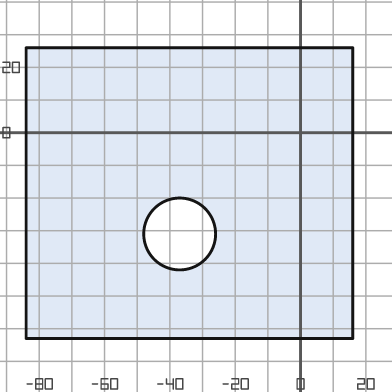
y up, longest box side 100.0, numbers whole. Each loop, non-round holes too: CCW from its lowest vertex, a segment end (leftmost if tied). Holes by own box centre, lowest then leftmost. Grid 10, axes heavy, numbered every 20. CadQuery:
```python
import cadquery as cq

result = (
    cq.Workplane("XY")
    .moveTo(-84.0, -63.0)
    .lineTo(16.0, -63.0)
    .lineTo(16.0, 26.0)
    .lineTo(-84.0, 26.0)
    .close()
    .moveTo(-37.0, -31.0)
    .circle(11.0)
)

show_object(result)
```